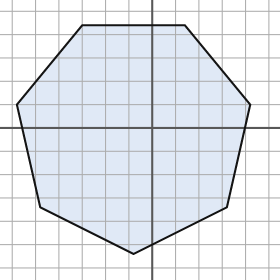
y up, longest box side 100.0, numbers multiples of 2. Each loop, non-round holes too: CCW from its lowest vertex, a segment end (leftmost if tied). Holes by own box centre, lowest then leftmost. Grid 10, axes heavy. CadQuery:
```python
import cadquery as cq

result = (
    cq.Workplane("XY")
    .moveTo(-8.0, -54.0)
    .lineTo(32.0, -34.0)
    .lineTo(42.0, 10.0)
    .lineTo(14.0, 44.0)
    .lineTo(-30.0, 44.0)
    .lineTo(-58.0, 10.0)
    .lineTo(-48.0, -34.0)
    .close()
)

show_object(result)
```